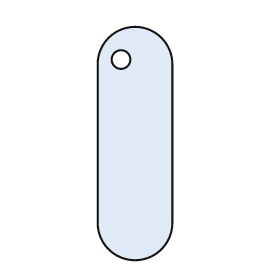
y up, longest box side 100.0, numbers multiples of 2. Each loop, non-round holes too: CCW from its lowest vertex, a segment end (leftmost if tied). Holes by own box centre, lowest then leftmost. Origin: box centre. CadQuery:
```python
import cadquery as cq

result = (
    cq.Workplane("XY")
    .moveTo(-16.0, -34.0)
    .threePointArc((0.0, -50.0), (16.0, -34.0))
    .lineTo(16.0, 34.0)
    .threePointArc((0.0, 50.0), (-16.0, 34.0))
    .close()
    .moveTo(-6.0, 36.0)
    .circle(4.0)
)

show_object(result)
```